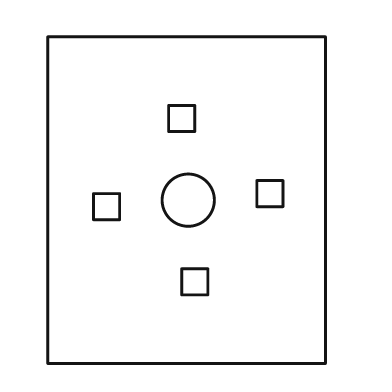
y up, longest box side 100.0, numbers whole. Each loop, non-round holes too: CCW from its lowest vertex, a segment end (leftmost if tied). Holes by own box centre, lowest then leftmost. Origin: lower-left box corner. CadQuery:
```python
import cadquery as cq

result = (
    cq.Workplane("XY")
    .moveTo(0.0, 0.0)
    .lineTo(85.0, 0.0)
    .lineTo(85.0, 100.0)
    .lineTo(0.0, 100.0)
    .close()
    .moveTo(41.0, 21.0)
    .lineTo(49.0, 21.0)
    .lineTo(49.0, 29.0)
    .lineTo(41.0, 29.0)
    .close()
    .moveTo(14.0, 44.0)
    .lineTo(22.0, 44.0)
    .lineTo(22.0, 52.0)
    .lineTo(14.0, 52.0)
    .close()
    .moveTo(43.0, 50.0)
    .circle(8.0)
    .moveTo(64.0, 48.0)
    .lineTo(72.0, 48.0)
    .lineTo(72.0, 56.0)
    .lineTo(64.0, 56.0)
    .close()
    .moveTo(37.0, 71.0)
    .lineTo(45.0, 71.0)
    .lineTo(45.0, 79.0)
    .lineTo(37.0, 79.0)
    .close()
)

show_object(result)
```